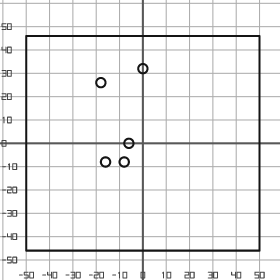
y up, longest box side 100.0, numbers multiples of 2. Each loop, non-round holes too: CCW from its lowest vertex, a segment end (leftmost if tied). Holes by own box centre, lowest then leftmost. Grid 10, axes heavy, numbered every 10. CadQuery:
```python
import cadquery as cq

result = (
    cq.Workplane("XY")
    .moveTo(-50.0, -46.0)
    .lineTo(50.0, -46.0)
    .lineTo(50.0, 46.0)
    .lineTo(-50.0, 46.0)
    .close()
    .moveTo(-16.0, -8.0)
    .circle(2.0)
    .moveTo(-8.0, -8.0)
    .circle(2.0)
    .moveTo(-6.0, 0.0)
    .circle(2.0)
    .moveTo(-18.0, 26.0)
    .circle(2.0)
    .moveTo(0.0, 32.0)
    .circle(2.0)
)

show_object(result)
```